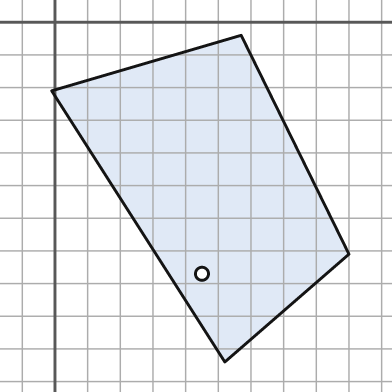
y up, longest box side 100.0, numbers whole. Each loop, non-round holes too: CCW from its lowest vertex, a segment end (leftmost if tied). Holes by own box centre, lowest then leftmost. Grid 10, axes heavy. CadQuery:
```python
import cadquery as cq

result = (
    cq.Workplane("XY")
    .moveTo(52.0, -104.0)
    .lineTo(90.0, -71.0)
    .lineTo(57.0, -4.0)
    .lineTo(-1.0, -21.0)
    .close()
    .moveTo(45.0, -77.0)
    .circle(2.0)
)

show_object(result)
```